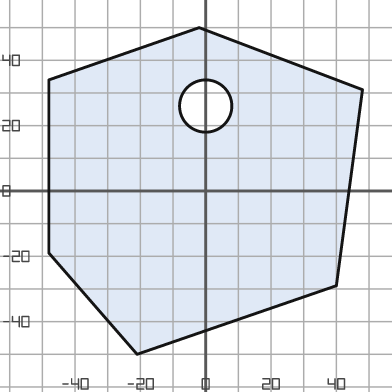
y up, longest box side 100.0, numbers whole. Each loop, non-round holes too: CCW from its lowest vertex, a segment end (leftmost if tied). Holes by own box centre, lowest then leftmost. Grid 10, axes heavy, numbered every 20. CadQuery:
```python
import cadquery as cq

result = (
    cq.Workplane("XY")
    .moveTo(-21.0, -50.0)
    .lineTo(40.0, -29.0)
    .lineTo(48.0, 31.0)
    .lineTo(-2.0, 50.0)
    .lineTo(-48.0, 34.0)
    .lineTo(-48.0, -19.0)
    .close()
    .moveTo(0.0, 26.0)
    .circle(8.0)
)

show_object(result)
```